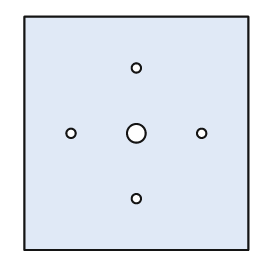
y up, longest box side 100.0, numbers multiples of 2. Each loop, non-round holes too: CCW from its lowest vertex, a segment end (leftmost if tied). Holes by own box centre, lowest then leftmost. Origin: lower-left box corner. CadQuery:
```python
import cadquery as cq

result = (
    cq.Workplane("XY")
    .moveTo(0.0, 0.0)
    .lineTo(96.0, 0.0)
    .lineTo(96.0, 100.0)
    .lineTo(0.0, 100.0)
    .close()
    .moveTo(48.0, 22.0)
    .circle(2.0)
    .moveTo(20.0, 50.0)
    .circle(2.0)
    .moveTo(48.0, 50.0)
    .circle(4.0)
    .moveTo(76.0, 50.0)
    .circle(2.0)
    .moveTo(48.0, 78.0)
    .circle(2.0)
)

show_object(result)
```